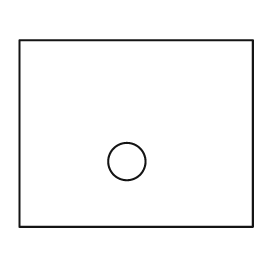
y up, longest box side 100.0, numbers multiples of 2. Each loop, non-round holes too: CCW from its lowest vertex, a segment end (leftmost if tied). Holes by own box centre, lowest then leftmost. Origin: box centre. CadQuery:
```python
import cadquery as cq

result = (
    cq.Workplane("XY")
    .moveTo(-50.0, -40.0)
    .lineTo(50.0, -40.0)
    .lineTo(50.0, 40.0)
    .lineTo(-50.0, 40.0)
    .close()
    .moveTo(-4.0, -12.0)
    .circle(8.0)
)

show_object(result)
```